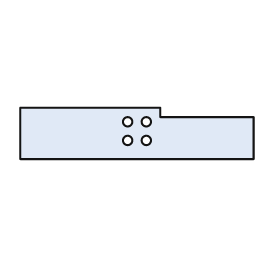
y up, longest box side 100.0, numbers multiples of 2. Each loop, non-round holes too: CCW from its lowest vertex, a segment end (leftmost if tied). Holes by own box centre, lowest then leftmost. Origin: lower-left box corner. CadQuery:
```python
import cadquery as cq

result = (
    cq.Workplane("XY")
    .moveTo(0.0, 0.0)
    .lineTo(100.0, 0.0)
    .lineTo(100.0, 18.0)
    .lineTo(60.0, 18.0)
    .lineTo(60.0, 22.0)
    .lineTo(0.0, 22.0)
    .close()
    .moveTo(46.0, 8.0)
    .circle(2.0)
    .moveTo(54.0, 8.0)
    .circle(2.0)
    .moveTo(46.0, 16.0)
    .circle(2.0)
    .moveTo(54.0, 16.0)
    .circle(2.0)
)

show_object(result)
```